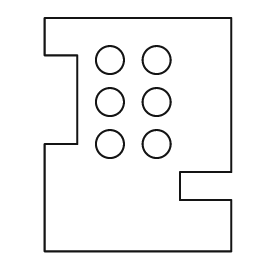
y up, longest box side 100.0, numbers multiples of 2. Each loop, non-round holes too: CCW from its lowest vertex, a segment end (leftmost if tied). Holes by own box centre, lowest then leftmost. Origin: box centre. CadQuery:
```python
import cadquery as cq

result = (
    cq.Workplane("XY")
    .moveTo(-40.0, -50.0)
    .lineTo(40.0, -50.0)
    .lineTo(40.0, -28.0)
    .lineTo(18.0, -28.0)
    .lineTo(18.0, -16.0)
    .lineTo(40.0, -16.0)
    .lineTo(40.0, 50.0)
    .lineTo(-40.0, 50.0)
    .lineTo(-40.0, 34.0)
    .lineTo(-26.0, 34.0)
    .lineTo(-26.0, -4.0)
    .lineTo(-40.0, -4.0)
    .close()
    .moveTo(-12.0, -4.0)
    .circle(6.0)
    .moveTo(8.0, -4.0)
    .circle(6.0)
    .moveTo(-12.0, 14.0)
    .circle(6.0)
    .moveTo(8.0, 14.0)
    .circle(6.0)
    .moveTo(-12.0, 32.0)
    .circle(6.0)
    .moveTo(8.0, 32.0)
    .circle(6.0)
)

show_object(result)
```